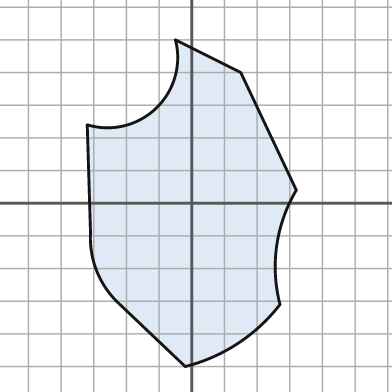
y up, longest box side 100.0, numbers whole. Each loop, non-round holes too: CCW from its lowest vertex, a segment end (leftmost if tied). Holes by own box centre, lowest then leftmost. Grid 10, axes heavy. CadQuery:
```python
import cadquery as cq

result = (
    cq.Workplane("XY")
    .moveTo(-2.0, -50.0)
    .threePointArc((14.0, -43.0), (27.0, -31.0))
    .threePointArc((26.0, -13.0), (32.0, 4.0))
    .lineTo(15.0, 40.0)
    .lineTo(-5.0, 50.0)
    .threePointArc((-11.0, 29.0), (-32.0, 24.0))
    .lineTo(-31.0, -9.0)
    .threePointArc((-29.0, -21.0), (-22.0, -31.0))
    .close()
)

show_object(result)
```